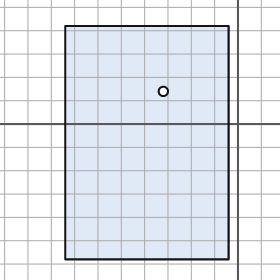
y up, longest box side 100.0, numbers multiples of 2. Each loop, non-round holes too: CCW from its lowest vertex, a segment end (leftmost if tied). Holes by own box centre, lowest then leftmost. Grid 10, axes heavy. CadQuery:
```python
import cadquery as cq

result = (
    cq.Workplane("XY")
    .moveTo(-74.0, -58.0)
    .lineTo(-4.0, -58.0)
    .lineTo(-4.0, 42.0)
    .lineTo(-74.0, 42.0)
    .close()
    .moveTo(-32.0, 14.0)
    .circle(2.0)
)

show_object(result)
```